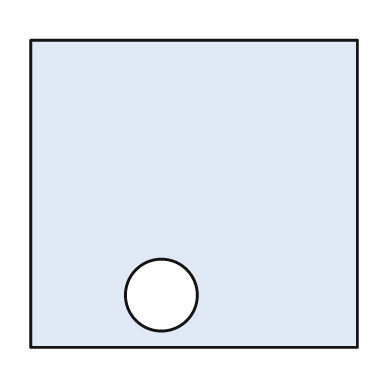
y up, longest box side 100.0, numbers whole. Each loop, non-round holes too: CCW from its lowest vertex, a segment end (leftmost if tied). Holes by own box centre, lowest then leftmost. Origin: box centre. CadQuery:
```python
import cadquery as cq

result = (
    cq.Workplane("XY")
    .moveTo(-50.0, -47.0)
    .lineTo(50.0, -47.0)
    .lineTo(50.0, 47.0)
    .lineTo(-50.0, 47.0)
    .close()
    .moveTo(-10.0, -31.0)
    .circle(11.0)
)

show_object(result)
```